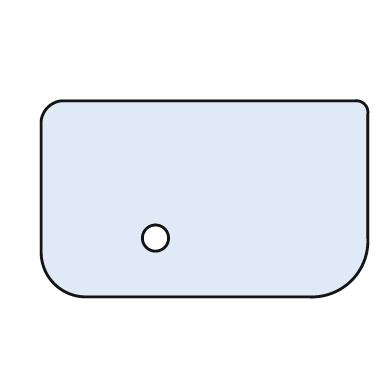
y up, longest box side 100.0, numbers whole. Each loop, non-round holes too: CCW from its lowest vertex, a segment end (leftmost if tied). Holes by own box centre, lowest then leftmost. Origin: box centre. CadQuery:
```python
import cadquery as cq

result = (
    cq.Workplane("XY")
    .moveTo(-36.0, -30.0)
    .lineTo(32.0, -30.0)
    .threePointArc((45.0, -25.0), (50.0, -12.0))
    .lineTo(50.0, 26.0)
    .threePointArc((49.0, 29.0), (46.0, 30.0))
    .lineTo(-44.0, 30.0)
    .threePointArc((-48.0, 28.0), (-50.0, 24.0))
    .lineTo(-50.0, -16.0)
    .threePointArc((-46.0, -26.0), (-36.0, -30.0))
    .close()
    .moveTo(-15.0, -12.0)
    .circle(4.0)
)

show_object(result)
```